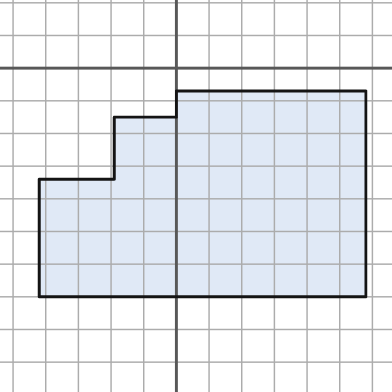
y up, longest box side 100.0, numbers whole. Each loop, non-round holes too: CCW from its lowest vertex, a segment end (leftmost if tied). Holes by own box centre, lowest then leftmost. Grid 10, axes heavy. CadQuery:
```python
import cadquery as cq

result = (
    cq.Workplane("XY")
    .moveTo(-42.0, -70.0)
    .lineTo(58.0, -70.0)
    .lineTo(58.0, -7.0)
    .lineTo(0.0, -7.0)
    .lineTo(0.0, -15.0)
    .lineTo(-19.0, -15.0)
    .lineTo(-19.0, -34.0)
    .lineTo(-42.0, -34.0)
    .close()
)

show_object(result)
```